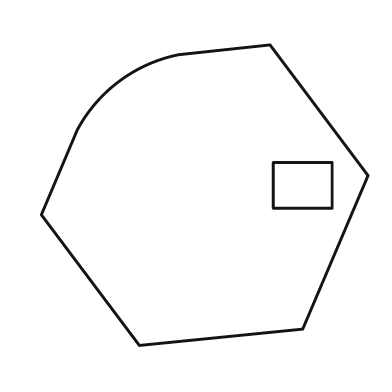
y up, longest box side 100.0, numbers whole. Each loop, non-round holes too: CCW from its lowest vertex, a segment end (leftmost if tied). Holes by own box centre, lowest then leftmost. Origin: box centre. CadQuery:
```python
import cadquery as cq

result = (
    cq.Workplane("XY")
    .moveTo(-20.0, -46.0)
    .lineTo(30.0, -41.0)
    .lineTo(50.0, 6.0)
    .lineTo(20.0, 46.0)
    .lineTo(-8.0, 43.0)
    .threePointArc((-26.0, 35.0), (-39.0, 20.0))
    .lineTo(-50.0, -6.0)
    .close()
    .moveTo(21.0, -4.0)
    .lineTo(39.0, -4.0)
    .lineTo(39.0, 10.0)
    .lineTo(21.0, 10.0)
    .close()
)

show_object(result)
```